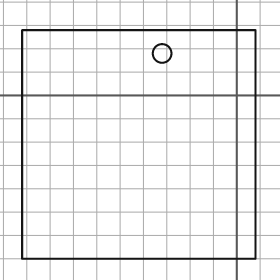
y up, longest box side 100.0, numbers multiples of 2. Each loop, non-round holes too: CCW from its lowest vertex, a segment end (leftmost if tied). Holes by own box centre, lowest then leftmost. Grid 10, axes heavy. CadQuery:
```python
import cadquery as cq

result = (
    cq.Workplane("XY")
    .moveTo(-92.0, -70.0)
    .lineTo(8.0, -70.0)
    .lineTo(8.0, 28.0)
    .lineTo(-92.0, 28.0)
    .close()
    .moveTo(-32.0, 18.0)
    .circle(4.0)
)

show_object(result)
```